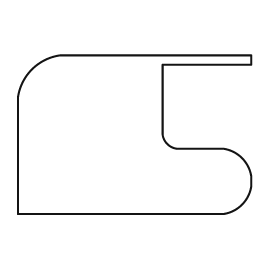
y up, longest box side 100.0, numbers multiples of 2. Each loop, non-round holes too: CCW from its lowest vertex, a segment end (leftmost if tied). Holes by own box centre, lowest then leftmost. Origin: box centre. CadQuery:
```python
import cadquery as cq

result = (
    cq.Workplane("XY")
    .moveTo(-50.0, -34.0)
    .lineTo(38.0, -34.0)
    .threePointArc((46.0, -30.0), (50.0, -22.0))
    .lineTo(50.0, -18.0)
    .threePointArc((46.0, -10.0), (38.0, -6.0))
    .lineTo(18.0, -6.0)
    .threePointArc((14.0, -4.0), (12.0, 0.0))
    .lineTo(12.0, 30.0)
    .lineTo(50.0, 30.0)
    .lineTo(50.0, 34.0)
    .lineTo(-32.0, 34.0)
    .threePointArc((-44.0, 28.0), (-50.0, 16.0))
    .close()
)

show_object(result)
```